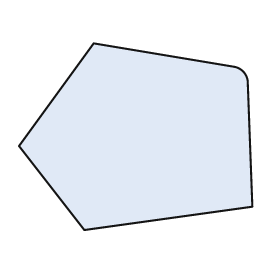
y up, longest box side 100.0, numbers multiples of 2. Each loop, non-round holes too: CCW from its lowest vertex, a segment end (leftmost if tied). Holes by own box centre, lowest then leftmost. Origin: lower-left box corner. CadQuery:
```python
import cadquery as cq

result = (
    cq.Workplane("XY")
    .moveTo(28.0, 0.0)
    .lineTo(100.0, 10.0)
    .lineTo(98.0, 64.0)
    .threePointArc((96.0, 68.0), (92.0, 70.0))
    .lineTo(32.0, 80.0)
    .lineTo(0.0, 36.0)
    .close()
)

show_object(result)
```